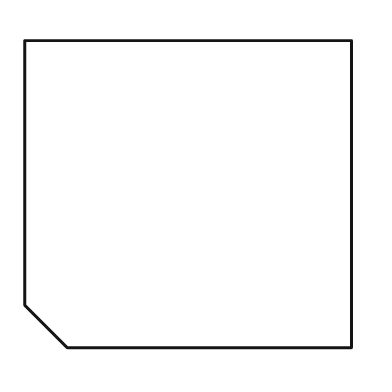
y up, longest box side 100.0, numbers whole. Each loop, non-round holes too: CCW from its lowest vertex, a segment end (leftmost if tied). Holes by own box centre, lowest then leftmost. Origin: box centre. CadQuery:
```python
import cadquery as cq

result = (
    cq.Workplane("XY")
    .moveTo(-37.0, -47.0)
    .lineTo(50.0, -47.0)
    .lineTo(50.0, 47.0)
    .lineTo(-50.0, 47.0)
    .lineTo(-50.0, -34.0)
    .close()
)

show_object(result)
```